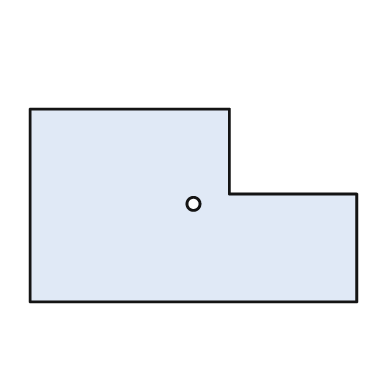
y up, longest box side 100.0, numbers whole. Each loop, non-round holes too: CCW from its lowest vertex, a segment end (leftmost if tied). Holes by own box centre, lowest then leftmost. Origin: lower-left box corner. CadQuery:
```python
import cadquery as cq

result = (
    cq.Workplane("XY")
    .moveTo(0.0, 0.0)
    .lineTo(100.0, 0.0)
    .lineTo(100.0, 33.0)
    .lineTo(61.0, 33.0)
    .lineTo(61.0, 59.0)
    .lineTo(0.0, 59.0)
    .close()
    .moveTo(50.0, 30.0)
    .circle(2.0)
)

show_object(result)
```